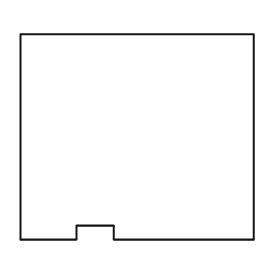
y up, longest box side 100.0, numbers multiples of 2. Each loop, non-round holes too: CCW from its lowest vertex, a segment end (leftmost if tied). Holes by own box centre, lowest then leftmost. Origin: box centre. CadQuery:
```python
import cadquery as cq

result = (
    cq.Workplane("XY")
    .moveTo(-50.0, -44.0)
    .lineTo(-26.0, -44.0)
    .lineTo(-26.0, -38.0)
    .lineTo(-10.0, -38.0)
    .lineTo(-10.0, -44.0)
    .lineTo(50.0, -44.0)
    .lineTo(50.0, 44.0)
    .lineTo(-50.0, 44.0)
    .close()
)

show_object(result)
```